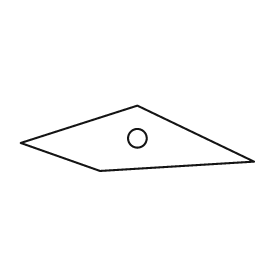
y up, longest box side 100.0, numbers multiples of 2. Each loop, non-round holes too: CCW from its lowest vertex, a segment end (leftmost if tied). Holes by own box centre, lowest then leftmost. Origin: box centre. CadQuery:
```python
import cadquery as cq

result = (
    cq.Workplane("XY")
    .moveTo(-16.0, -14.0)
    .lineTo(50.0, -10.0)
    .lineTo(0.0, 14.0)
    .lineTo(-50.0, -2.0)
    .close()
    .moveTo(0.0, 0.0)
    .circle(4.0)
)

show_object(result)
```